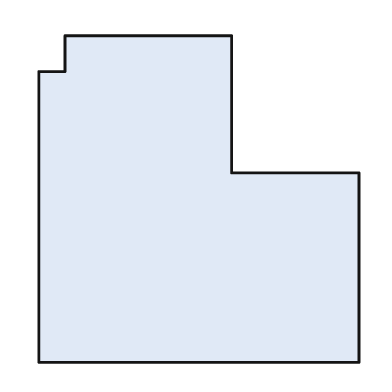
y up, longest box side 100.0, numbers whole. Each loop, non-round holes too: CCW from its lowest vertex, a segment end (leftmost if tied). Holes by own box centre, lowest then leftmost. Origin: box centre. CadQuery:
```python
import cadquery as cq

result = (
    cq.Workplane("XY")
    .moveTo(-49.0, -50.0)
    .lineTo(49.0, -50.0)
    .lineTo(49.0, 8.0)
    .lineTo(10.0, 8.0)
    .lineTo(10.0, 50.0)
    .lineTo(-41.0, 50.0)
    .lineTo(-41.0, 39.0)
    .lineTo(-49.0, 39.0)
    .close()
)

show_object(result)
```